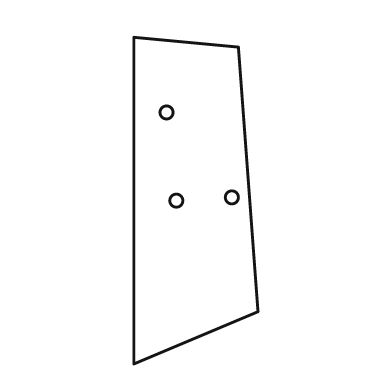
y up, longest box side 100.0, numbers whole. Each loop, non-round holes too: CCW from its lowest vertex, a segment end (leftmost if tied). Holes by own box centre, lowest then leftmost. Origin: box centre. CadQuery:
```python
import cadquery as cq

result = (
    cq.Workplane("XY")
    .moveTo(-19.0, -50.0)
    .lineTo(19.0, -34.0)
    .lineTo(13.0, 47.0)
    .lineTo(-19.0, 50.0)
    .close()
    .moveTo(-6.0, 0.0)
    .circle(2.0)
    .moveTo(11.0, 1.0)
    .circle(2.0)
    .moveTo(-9.0, 27.0)
    .circle(2.0)
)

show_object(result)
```